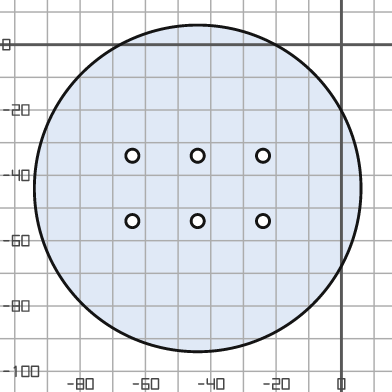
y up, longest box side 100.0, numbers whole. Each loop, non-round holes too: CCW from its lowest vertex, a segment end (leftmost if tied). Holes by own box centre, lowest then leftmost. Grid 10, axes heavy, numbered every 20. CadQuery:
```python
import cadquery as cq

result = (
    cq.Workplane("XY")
    .moveTo(-44.0, -44.0)
    .circle(50.0)
    .moveTo(-64.0, -54.0)
    .circle(2.0)
    .moveTo(-44.0, -54.0)
    .circle(2.0)
    .moveTo(-24.0, -54.0)
    .circle(2.0)
    .moveTo(-64.0, -34.0)
    .circle(2.0)
    .moveTo(-44.0, -34.0)
    .circle(2.0)
    .moveTo(-24.0, -34.0)
    .circle(2.0)
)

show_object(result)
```